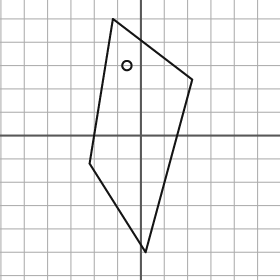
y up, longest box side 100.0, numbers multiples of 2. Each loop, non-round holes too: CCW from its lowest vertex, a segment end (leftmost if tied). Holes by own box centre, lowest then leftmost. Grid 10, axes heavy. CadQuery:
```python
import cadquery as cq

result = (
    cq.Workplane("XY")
    .moveTo(2.0, -50.0)
    .lineTo(22.0, 24.0)
    .lineTo(-12.0, 50.0)
    .lineTo(-22.0, -12.0)
    .close()
    .moveTo(-6.0, 30.0)
    .circle(2.0)
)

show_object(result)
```